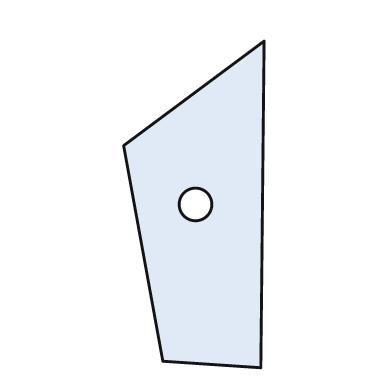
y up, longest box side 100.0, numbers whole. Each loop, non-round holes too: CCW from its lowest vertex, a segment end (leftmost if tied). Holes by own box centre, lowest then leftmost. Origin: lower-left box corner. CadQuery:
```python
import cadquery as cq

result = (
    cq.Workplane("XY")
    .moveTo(42.0, 0.0)
    .lineTo(43.0, 100.0)
    .lineTo(0.0, 68.0)
    .lineTo(12.0, 2.0)
    .close()
    .moveTo(22.0, 50.0)
    .circle(5.0)
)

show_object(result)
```